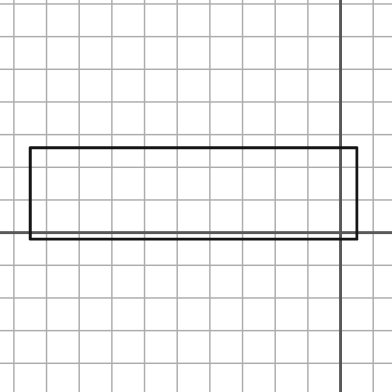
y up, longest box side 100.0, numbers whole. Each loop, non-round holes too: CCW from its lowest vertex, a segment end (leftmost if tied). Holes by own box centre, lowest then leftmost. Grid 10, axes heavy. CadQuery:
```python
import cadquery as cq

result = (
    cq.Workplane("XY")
    .moveTo(-95.0, -2.0)
    .lineTo(5.0, -2.0)
    .lineTo(5.0, 26.0)
    .lineTo(-95.0, 26.0)
    .close()
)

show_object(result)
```